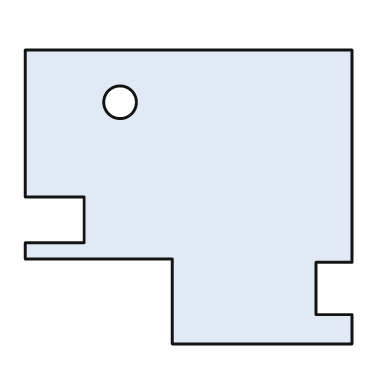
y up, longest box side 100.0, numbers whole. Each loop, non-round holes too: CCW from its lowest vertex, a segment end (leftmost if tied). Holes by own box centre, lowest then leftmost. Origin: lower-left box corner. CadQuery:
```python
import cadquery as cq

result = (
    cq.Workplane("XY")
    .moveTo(45.0, 0.0)
    .lineTo(100.0, 0.0)
    .lineTo(100.0, 9.0)
    .lineTo(89.0, 9.0)
    .lineTo(89.0, 25.0)
    .lineTo(100.0, 25.0)
    .lineTo(100.0, 90.0)
    .lineTo(0.0, 90.0)
    .lineTo(0.0, 45.0)
    .lineTo(18.0, 45.0)
    .lineTo(18.0, 31.0)
    .lineTo(0.0, 31.0)
    .lineTo(0.0, 26.0)
    .lineTo(45.0, 26.0)
    .close()
    .moveTo(29.0, 74.0)
    .circle(5.0)
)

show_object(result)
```